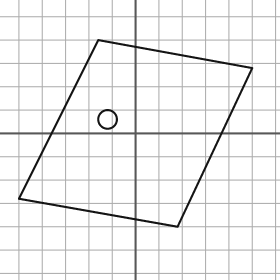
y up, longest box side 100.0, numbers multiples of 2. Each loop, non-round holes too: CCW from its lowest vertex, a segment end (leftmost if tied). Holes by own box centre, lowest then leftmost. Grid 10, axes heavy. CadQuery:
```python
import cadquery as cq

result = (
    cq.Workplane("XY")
    .moveTo(18.0, -40.0)
    .lineTo(50.0, 28.0)
    .lineTo(-16.0, 40.0)
    .lineTo(-50.0, -28.0)
    .close()
    .moveTo(-12.0, 6.0)
    .circle(4.0)
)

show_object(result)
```